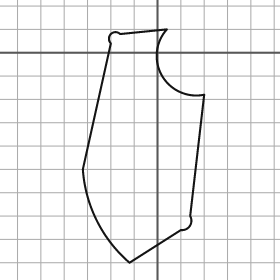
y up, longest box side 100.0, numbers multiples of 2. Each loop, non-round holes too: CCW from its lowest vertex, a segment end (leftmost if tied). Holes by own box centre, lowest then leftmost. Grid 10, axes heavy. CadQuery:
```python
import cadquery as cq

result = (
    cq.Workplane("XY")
    .moveTo(-12.0, -90.0)
    .lineTo(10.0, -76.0)
    .threePointArc((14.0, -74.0), (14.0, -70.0))
    .lineTo(20.0, -18.0)
    .threePointArc((2.0, -10.0), (4.0, 10.0))
    .lineTo(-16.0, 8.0)
    .threePointArc((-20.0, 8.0), (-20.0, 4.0))
    .lineTo(-32.0, -50.0)
    .threePointArc((-26.0, -72.0), (-12.0, -90.0))
    .close()
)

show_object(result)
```